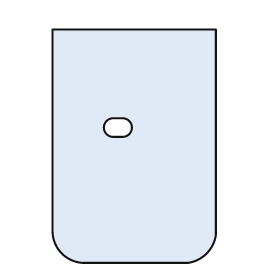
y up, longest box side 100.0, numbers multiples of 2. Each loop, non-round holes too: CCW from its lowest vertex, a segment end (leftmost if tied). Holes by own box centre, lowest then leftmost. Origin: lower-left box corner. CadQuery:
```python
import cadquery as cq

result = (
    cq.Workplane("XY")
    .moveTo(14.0, 0.0)
    .lineTo(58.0, 0.0)
    .threePointArc((66.0, 4.0), (70.0, 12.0))
    .lineTo(70.0, 100.0)
    .lineTo(0.0, 100.0)
    .lineTo(0.0, 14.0)
    .threePointArc((4.0, 4.0), (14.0, 0.0))
    .close()
    .moveTo(26.0, 54.0)
    .lineTo(30.0, 54.0)
    .threePointArc((34.0, 58.0), (30.0, 62.0))
    .lineTo(26.0, 62.0)
    .threePointArc((22.0, 58.0), (26.0, 54.0))
    .close()
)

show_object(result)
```